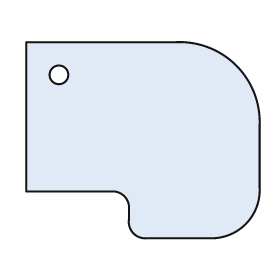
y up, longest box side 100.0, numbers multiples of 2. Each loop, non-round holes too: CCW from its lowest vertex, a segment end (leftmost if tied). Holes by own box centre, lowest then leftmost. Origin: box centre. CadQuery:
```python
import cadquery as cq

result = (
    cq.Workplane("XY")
    .moveTo(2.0, -42.0)
    .lineTo(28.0, -42.0)
    .threePointArc((44.0, -36.0), (50.0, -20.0))
    .lineTo(50.0, 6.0)
    .threePointArc((40.0, 32.0), (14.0, 42.0))
    .lineTo(-50.0, 42.0)
    .lineTo(-50.0, -22.0)
    .lineTo(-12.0, -22.0)
    .threePointArc((-8.0, -24.0), (-6.0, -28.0))
    .lineTo(-6.0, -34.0)
    .threePointArc((-4.0, -40.0), (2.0, -42.0))
    .close()
    .moveTo(-36.0, 28.0)
    .circle(4.0)
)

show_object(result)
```